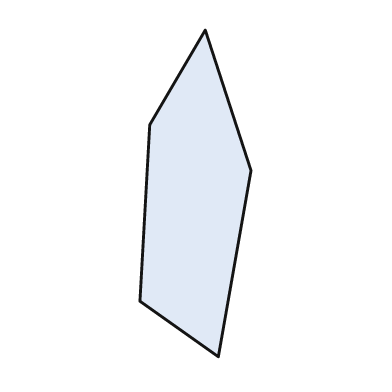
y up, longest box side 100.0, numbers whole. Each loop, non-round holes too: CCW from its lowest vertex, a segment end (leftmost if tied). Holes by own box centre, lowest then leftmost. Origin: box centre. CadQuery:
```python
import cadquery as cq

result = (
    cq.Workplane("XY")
    .moveTo(7.0, -50.0)
    .lineTo(17.0, 7.0)
    .lineTo(3.0, 50.0)
    .lineTo(-14.0, 21.0)
    .lineTo(-17.0, -33.0)
    .close()
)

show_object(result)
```